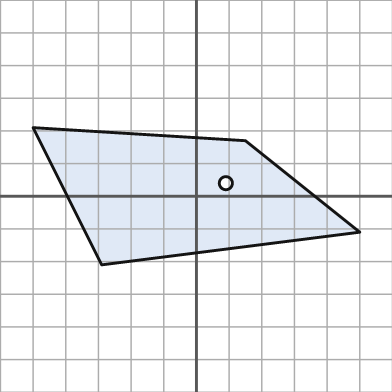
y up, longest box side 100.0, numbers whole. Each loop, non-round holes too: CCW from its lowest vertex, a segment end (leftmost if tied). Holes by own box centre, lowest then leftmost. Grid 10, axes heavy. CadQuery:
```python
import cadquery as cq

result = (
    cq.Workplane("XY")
    .moveTo(-29.0, -21.0)
    .lineTo(50.0, -11.0)
    .lineTo(15.0, 17.0)
    .lineTo(-50.0, 21.0)
    .close()
    .moveTo(9.0, 4.0)
    .circle(2.0)
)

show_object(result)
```